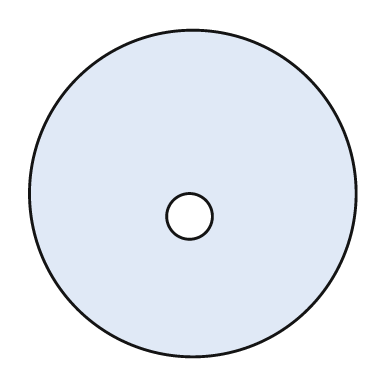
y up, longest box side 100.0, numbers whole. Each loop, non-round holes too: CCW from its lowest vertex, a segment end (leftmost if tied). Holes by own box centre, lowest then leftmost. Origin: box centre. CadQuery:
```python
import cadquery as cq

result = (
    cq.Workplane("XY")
    .moveTo(0.0, 0.0)
    .circle(50.0)
    .moveTo(-1.0, -7.0)
    .circle(7.0)
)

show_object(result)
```